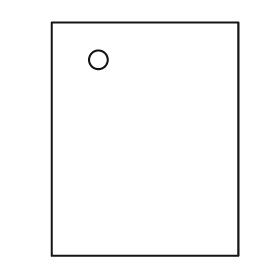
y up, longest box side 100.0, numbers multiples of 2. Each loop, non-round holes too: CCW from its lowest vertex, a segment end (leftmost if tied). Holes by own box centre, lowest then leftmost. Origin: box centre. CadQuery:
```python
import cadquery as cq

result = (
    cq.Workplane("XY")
    .moveTo(-40.0, -50.0)
    .lineTo(40.0, -50.0)
    .lineTo(40.0, 50.0)
    .lineTo(-40.0, 50.0)
    .close()
    .moveTo(-20.0, 34.0)
    .circle(4.0)
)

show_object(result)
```